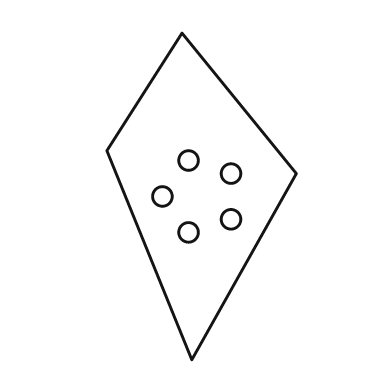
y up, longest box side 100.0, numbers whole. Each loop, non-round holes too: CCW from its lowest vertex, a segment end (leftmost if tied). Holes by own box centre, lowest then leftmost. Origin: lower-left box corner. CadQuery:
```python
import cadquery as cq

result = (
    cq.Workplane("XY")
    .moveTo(26.0, 0.0)
    .lineTo(58.0, 57.0)
    .lineTo(23.0, 100.0)
    .lineTo(0.0, 64.0)
    .close()
    .moveTo(25.0, 39.0)
    .circle(3.0)
    .moveTo(38.0, 43.0)
    .circle(3.0)
    .moveTo(17.0, 50.0)
    .circle(3.0)
    .moveTo(38.0, 57.0)
    .circle(3.0)
    .moveTo(25.0, 61.0)
    .circle(3.0)
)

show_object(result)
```